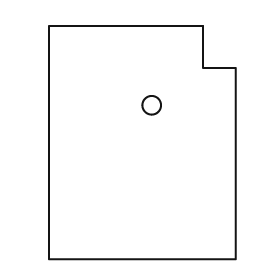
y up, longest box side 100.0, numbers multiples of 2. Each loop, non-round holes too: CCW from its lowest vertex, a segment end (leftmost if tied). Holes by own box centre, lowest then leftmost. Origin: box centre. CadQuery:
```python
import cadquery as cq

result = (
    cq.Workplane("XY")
    .moveTo(-40.0, -50.0)
    .lineTo(40.0, -50.0)
    .lineTo(40.0, 32.0)
    .lineTo(26.0, 32.0)
    .lineTo(26.0, 50.0)
    .lineTo(-40.0, 50.0)
    .close()
    .moveTo(4.0, 16.0)
    .circle(4.0)
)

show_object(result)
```